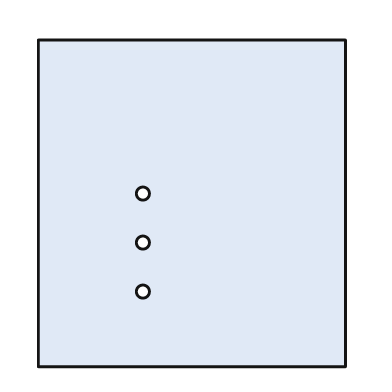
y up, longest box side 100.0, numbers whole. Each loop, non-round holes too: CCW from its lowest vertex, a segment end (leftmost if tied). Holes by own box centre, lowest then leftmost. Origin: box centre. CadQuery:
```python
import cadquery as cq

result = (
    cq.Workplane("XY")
    .moveTo(-47.0, -50.0)
    .lineTo(47.0, -50.0)
    .lineTo(47.0, 50.0)
    .lineTo(-47.0, 50.0)
    .close()
    .moveTo(-15.0, -27.0)
    .circle(2.0)
    .moveTo(-15.0, -12.0)
    .circle(2.0)
    .moveTo(-15.0, 3.0)
    .circle(2.0)
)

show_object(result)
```